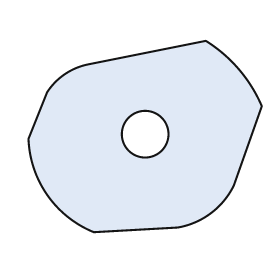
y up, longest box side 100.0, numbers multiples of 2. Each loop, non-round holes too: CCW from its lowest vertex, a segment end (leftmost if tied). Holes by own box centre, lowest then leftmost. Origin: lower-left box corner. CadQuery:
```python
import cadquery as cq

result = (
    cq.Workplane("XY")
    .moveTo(28.0, 0.0)
    .lineTo(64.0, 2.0)
    .threePointArc((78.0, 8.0), (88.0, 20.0))
    .lineTo(100.0, 54.0)
    .threePointArc((90.0, 70.0), (76.0, 82.0))
    .lineTo(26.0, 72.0)
    .threePointArc((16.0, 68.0), (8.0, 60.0))
    .lineTo(0.0, 40.0)
    .threePointArc((8.0, 16.0), (28.0, 0.0))
    .close()
    .moveTo(50.0, 42.0)
    .circle(10.0)
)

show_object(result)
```